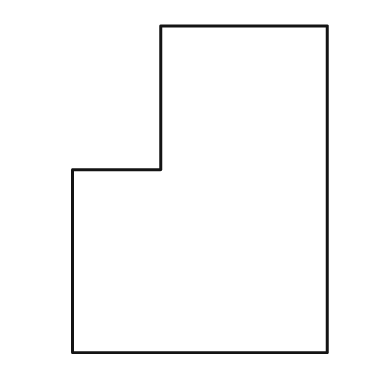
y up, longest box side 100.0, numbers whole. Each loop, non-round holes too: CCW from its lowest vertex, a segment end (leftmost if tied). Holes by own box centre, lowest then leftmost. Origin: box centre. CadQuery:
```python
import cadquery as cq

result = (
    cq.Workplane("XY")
    .moveTo(-39.0, -50.0)
    .lineTo(39.0, -50.0)
    .lineTo(39.0, 50.0)
    .lineTo(-12.0, 50.0)
    .lineTo(-12.0, 6.0)
    .lineTo(-39.0, 6.0)
    .close()
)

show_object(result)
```